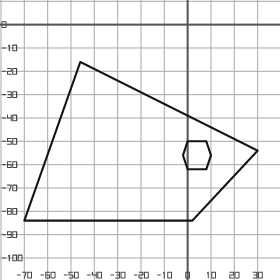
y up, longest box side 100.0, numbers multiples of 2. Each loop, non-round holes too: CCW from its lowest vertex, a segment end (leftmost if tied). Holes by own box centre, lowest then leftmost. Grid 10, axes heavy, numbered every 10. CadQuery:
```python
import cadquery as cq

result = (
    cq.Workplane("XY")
    .moveTo(-70.0, -84.0)
    .lineTo(2.0, -84.0)
    .lineTo(30.0, -54.0)
    .lineTo(-46.0, -16.0)
    .close()
    .moveTo(0.0, -62.0)
    .lineTo(8.0, -62.0)
    .lineTo(10.0, -56.0)
    .lineTo(8.0, -50.0)
    .lineTo(0.0, -50.0)
    .lineTo(-2.0, -56.0)
    .close()
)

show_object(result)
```